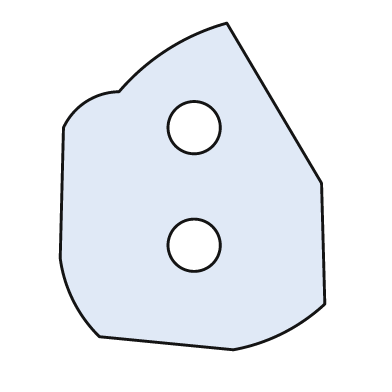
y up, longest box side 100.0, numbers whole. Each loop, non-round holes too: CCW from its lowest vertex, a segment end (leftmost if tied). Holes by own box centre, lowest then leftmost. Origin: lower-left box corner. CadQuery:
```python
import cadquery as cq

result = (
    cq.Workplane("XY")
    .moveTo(53.0, 0.0)
    .threePointArc((68.0, 5.0), (81.0, 14.0))
    .lineTo(80.0, 51.0)
    .lineTo(51.0, 100.0)
    .threePointArc((33.0, 92.0), (18.0, 79.0))
    .threePointArc((8.0, 76.0), (1.0, 68.0))
    .lineTo(0.0, 28.0)
    .threePointArc((4.0, 15.0), (12.0, 4.0))
    .close()
    .moveTo(41.0, 32.0)
    .circle(8.0)
    .moveTo(41.0, 68.0)
    .circle(8.0)
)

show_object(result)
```